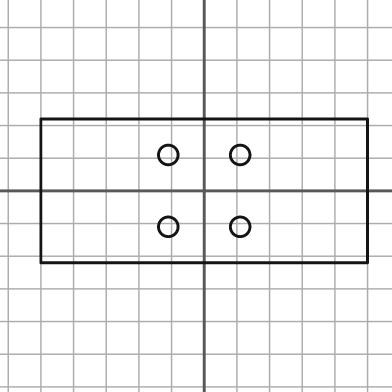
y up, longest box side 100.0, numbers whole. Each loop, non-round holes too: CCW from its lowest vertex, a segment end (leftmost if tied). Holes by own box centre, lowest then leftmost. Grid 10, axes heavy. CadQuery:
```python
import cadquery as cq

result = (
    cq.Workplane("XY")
    .moveTo(-50.0, -22.0)
    .lineTo(50.0, -22.0)
    .lineTo(50.0, 22.0)
    .lineTo(-50.0, 22.0)
    .close()
    .moveTo(-11.0, -11.0)
    .circle(3.0)
    .moveTo(11.0, -11.0)
    .circle(3.0)
    .moveTo(-11.0, 11.0)
    .circle(3.0)
    .moveTo(11.0, 11.0)
    .circle(3.0)
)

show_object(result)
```